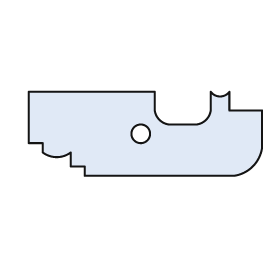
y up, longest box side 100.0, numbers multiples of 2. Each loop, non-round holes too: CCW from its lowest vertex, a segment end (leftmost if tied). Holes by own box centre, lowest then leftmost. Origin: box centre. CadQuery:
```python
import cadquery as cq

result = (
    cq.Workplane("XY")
    .moveTo(-26.0, -18.0)
    .lineTo(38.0, -18.0)
    .threePointArc((46.0, -14.0), (50.0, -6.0))
    .lineTo(50.0, 10.0)
    .lineTo(36.0, 10.0)
    .lineTo(36.0, 18.0)
    .threePointArc((32.0, 16.0), (28.0, 18.0))
    .lineTo(28.0, 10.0)
    .threePointArc((26.0, 6.0), (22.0, 4.0))
    .lineTo(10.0, 4.0)
    .threePointArc((6.0, 6.0), (4.0, 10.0))
    .lineTo(4.0, 18.0)
    .lineTo(-50.0, 18.0)
    .lineTo(-50.0, -4.0)
    .lineTo(-44.0, -4.0)
    .lineTo(-44.0, -8.0)
    .threePointArc((-38.0, -10.0), (-32.0, -8.0))
    .lineTo(-32.0, -14.0)
    .lineTo(-26.0, -14.0)
    .close()
    .moveTo(-2.0, 0.0)
    .circle(4.0)
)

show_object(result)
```